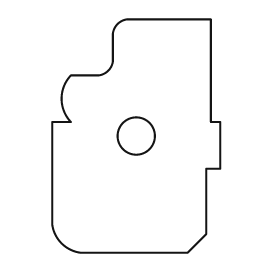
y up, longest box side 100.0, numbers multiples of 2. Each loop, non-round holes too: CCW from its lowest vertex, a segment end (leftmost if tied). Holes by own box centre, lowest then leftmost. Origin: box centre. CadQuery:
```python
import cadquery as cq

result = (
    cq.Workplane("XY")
    .moveTo(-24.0, -50.0)
    .lineTo(22.0, -50.0)
    .lineTo(30.0, -42.0)
    .lineTo(30.0, -14.0)
    .lineTo(36.0, -14.0)
    .lineTo(36.0, 6.0)
    .lineTo(32.0, 6.0)
    .lineTo(32.0, 50.0)
    .lineTo(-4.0, 50.0)
    .threePointArc((-8.0, 48.0), (-10.0, 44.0))
    .lineTo(-10.0, 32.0)
    .threePointArc((-12.0, 28.0), (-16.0, 26.0))
    .lineTo(-28.0, 26.0)
    .threePointArc((-32.0, 16.0), (-28.0, 6.0))
    .lineTo(-36.0, 6.0)
    .lineTo(-36.0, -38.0)
    .threePointArc((-32.0, -46.0), (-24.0, -50.0))
    .close()
    .moveTo(0.0, 0.0)
    .circle(8.0)
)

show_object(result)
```